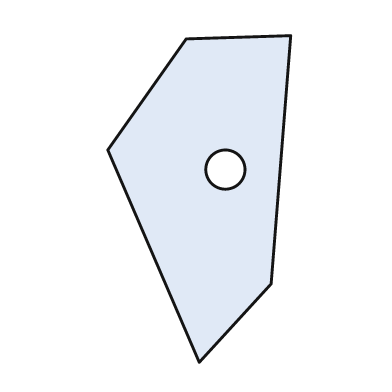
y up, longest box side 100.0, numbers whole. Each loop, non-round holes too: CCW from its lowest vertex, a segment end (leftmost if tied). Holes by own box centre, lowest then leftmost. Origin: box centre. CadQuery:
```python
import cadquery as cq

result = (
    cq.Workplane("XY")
    .moveTo(0.0, -50.0)
    .lineTo(22.0, -26.0)
    .lineTo(28.0, 50.0)
    .lineTo(-4.0, 49.0)
    .lineTo(-28.0, 15.0)
    .close()
    .moveTo(8.0, 9.0)
    .circle(6.0)
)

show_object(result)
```